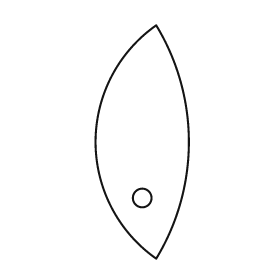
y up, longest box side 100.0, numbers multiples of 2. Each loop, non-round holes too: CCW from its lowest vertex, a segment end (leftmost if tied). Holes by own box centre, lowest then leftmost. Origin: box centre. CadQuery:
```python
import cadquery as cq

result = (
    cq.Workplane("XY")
    .moveTo(6.0, -50.0)
    .threePointArc((20.0, 0.0), (6.0, 50.0))
    .threePointArc((-20.0, 0.0), (6.0, -50.0))
    .close()
    .moveTo(0.0, -24.0)
    .circle(4.0)
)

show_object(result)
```